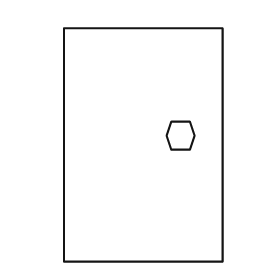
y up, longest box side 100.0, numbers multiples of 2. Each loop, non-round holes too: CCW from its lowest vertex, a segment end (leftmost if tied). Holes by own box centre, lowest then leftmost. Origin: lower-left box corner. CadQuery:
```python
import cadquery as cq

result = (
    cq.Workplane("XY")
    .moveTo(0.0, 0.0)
    .lineTo(68.0, 0.0)
    .lineTo(68.0, 100.0)
    .lineTo(0.0, 100.0)
    .close()
    .moveTo(46.0, 48.0)
    .lineTo(54.0, 48.0)
    .lineTo(56.0, 54.0)
    .lineTo(54.0, 60.0)
    .lineTo(46.0, 60.0)
    .lineTo(44.0, 54.0)
    .close()
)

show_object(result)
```